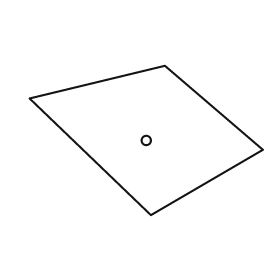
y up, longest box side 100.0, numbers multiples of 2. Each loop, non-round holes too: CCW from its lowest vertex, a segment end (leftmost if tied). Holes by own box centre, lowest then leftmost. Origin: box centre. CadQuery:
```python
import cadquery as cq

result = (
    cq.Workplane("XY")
    .moveTo(2.0, -32.0)
    .lineTo(50.0, -4.0)
    .lineTo(8.0, 32.0)
    .lineTo(-50.0, 18.0)
    .close()
    .moveTo(0.0, 0.0)
    .circle(2.0)
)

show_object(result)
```